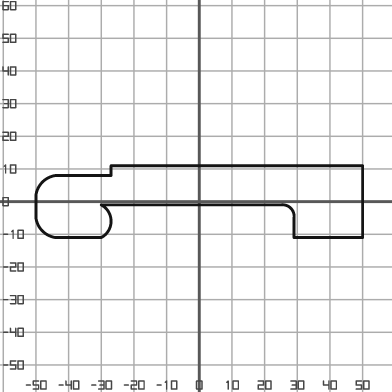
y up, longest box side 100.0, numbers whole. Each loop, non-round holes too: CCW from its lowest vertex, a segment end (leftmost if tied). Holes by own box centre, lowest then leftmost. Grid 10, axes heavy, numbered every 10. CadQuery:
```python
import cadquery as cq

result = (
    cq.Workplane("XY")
    .moveTo(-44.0, -11.0)
    .lineTo(-30.0, -11.0)
    .threePointArc((-27.0, -6.0), (-30.0, -1.0))
    .lineTo(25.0, -1.0)
    .threePointArc((28.0, -2.0), (29.0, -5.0))
    .lineTo(29.0, -11.0)
    .lineTo(50.0, -11.0)
    .lineTo(50.0, 11.0)
    .lineTo(-27.0, 11.0)
    .lineTo(-27.0, 8.0)
    .lineTo(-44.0, 8.0)
    .threePointArc((-48.0, 6.0), (-50.0, 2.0))
    .lineTo(-50.0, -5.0)
    .threePointArc((-48.0, -9.0), (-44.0, -11.0))
    .close()
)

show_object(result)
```